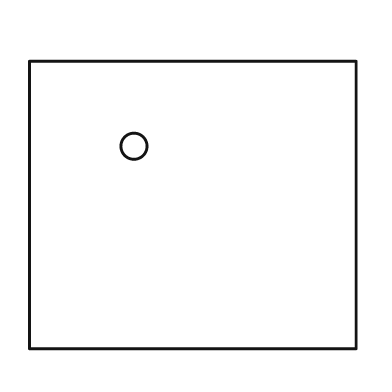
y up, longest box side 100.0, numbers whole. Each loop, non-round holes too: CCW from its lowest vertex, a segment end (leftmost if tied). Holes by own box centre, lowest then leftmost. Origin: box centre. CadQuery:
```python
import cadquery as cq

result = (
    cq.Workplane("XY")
    .moveTo(-50.0, -44.0)
    .lineTo(50.0, -44.0)
    .lineTo(50.0, 44.0)
    .lineTo(-50.0, 44.0)
    .close()
    .moveTo(-18.0, 18.0)
    .circle(4.0)
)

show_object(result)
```